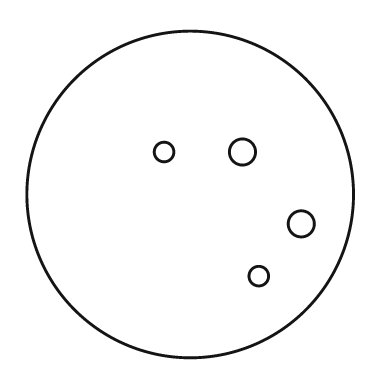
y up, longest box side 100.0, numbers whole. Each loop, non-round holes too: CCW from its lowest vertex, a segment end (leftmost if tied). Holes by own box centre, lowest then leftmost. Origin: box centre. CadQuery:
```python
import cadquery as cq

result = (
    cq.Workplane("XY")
    .moveTo(0.0, 0.0)
    .circle(50.0)
    .moveTo(21.0, -25.0)
    .circle(3.0)
    .moveTo(34.0, -9.0)
    .circle(4.0)
    .moveTo(-8.0, 13.0)
    .circle(3.0)
    .moveTo(16.0, 13.0)
    .circle(4.0)
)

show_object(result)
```